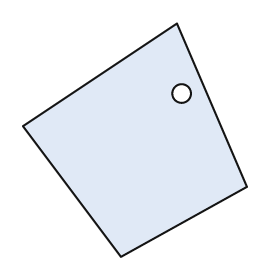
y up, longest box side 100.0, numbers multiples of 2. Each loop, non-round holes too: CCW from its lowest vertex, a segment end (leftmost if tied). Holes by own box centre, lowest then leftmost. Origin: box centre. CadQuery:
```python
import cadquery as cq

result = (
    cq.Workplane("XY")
    .moveTo(-6.0, -50.0)
    .lineTo(48.0, -20.0)
    .lineTo(18.0, 50.0)
    .lineTo(-48.0, 6.0)
    .close()
    .moveTo(20.0, 20.0)
    .circle(4.0)
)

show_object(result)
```